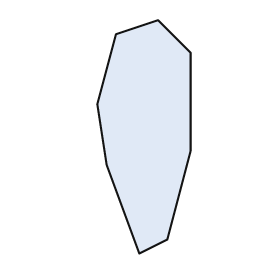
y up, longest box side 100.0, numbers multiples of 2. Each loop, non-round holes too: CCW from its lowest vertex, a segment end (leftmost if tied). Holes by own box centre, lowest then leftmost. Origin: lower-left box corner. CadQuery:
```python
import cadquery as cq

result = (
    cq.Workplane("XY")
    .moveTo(18.0, 0.0)
    .lineTo(30.0, 6.0)
    .lineTo(40.0, 44.0)
    .lineTo(40.0, 86.0)
    .lineTo(26.0, 100.0)
    .lineTo(8.0, 94.0)
    .lineTo(0.0, 64.0)
    .lineTo(4.0, 38.0)
    .close()
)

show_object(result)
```